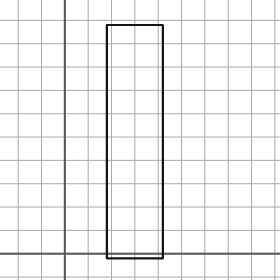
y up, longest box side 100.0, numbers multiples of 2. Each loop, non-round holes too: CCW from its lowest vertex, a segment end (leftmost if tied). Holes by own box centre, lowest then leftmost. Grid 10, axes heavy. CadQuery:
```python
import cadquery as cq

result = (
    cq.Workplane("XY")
    .moveTo(18.0, -2.0)
    .lineTo(42.0, -2.0)
    .lineTo(42.0, 98.0)
    .lineTo(18.0, 98.0)
    .close()
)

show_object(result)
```